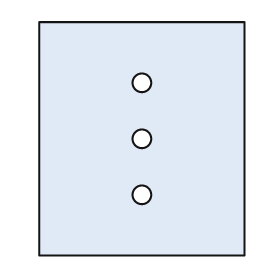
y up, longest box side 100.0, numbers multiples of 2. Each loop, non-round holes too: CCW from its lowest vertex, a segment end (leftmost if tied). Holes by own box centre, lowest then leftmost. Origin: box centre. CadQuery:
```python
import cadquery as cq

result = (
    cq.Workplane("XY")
    .moveTo(-44.0, -50.0)
    .lineTo(44.0, -50.0)
    .lineTo(44.0, 50.0)
    .lineTo(-44.0, 50.0)
    .close()
    .moveTo(0.0, -24.0)
    .circle(4.0)
    .moveTo(0.0, 0.0)
    .circle(4.0)
    .moveTo(0.0, 24.0)
    .circle(4.0)
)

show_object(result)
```